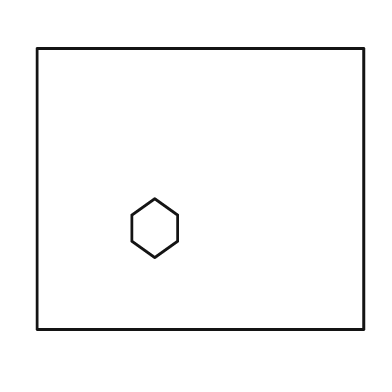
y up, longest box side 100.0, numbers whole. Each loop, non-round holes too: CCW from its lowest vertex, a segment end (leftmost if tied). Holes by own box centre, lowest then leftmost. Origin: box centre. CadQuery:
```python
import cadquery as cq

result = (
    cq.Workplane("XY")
    .moveTo(-50.0, -43.0)
    .lineTo(50.0, -43.0)
    .lineTo(50.0, 43.0)
    .lineTo(-50.0, 43.0)
    .close()
    .moveTo(-14.0, -21.0)
    .lineTo(-7.0, -16.0)
    .lineTo(-7.0, -8.0)
    .lineTo(-14.0, -3.0)
    .lineTo(-21.0, -8.0)
    .lineTo(-21.0, -16.0)
    .close()
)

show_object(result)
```